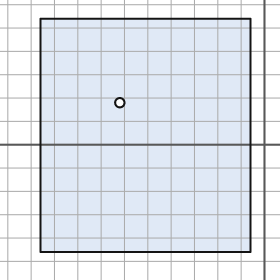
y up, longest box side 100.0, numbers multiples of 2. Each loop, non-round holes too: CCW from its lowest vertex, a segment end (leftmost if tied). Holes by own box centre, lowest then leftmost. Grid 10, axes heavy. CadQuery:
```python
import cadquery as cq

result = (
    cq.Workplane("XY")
    .moveTo(-96.0, -46.0)
    .lineTo(-6.0, -46.0)
    .lineTo(-6.0, 54.0)
    .lineTo(-96.0, 54.0)
    .close()
    .moveTo(-62.0, 18.0)
    .circle(2.0)
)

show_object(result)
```